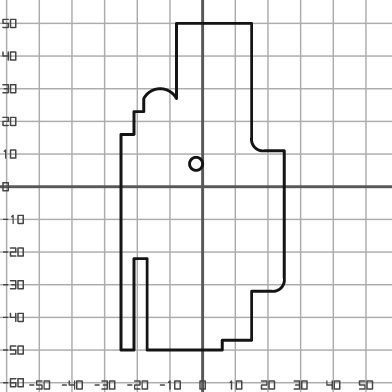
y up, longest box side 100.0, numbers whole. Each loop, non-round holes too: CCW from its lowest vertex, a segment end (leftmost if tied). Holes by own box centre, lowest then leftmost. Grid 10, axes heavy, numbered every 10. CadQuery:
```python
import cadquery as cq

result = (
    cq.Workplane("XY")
    .moveTo(-25.0, -50.0)
    .lineTo(-21.0, -50.0)
    .lineTo(-21.0, -22.0)
    .lineTo(-17.0, -22.0)
    .lineTo(-17.0, -50.0)
    .lineTo(6.0, -50.0)
    .lineTo(6.0, -47.0)
    .lineTo(15.0, -47.0)
    .lineTo(15.0, -32.0)
    .lineTo(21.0, -32.0)
    .threePointArc((24.0, -31.0), (25.0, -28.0))
    .lineTo(25.0, 11.0)
    .lineTo(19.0, 11.0)
    .threePointArc((16.0, 12.0), (15.0, 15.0))
    .lineTo(15.0, 50.0)
    .lineTo(-8.0, 50.0)
    .lineTo(-8.0, 27.0)
    .threePointArc((-13.0, 30.0), (-18.0, 27.0))
    .lineTo(-18.0, 23.0)
    .lineTo(-21.0, 23.0)
    .lineTo(-21.0, 16.0)
    .lineTo(-25.0, 16.0)
    .close()
    .moveTo(-2.0, 7.0)
    .circle(2.0)
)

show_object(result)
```